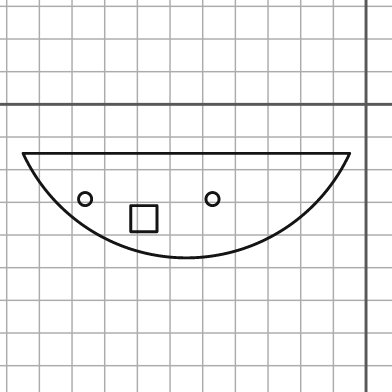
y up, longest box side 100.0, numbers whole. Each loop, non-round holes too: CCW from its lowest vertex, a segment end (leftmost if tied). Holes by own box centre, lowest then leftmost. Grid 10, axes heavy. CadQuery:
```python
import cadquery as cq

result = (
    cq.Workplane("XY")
    .moveTo(-105.0, -15.0)
    .threePointArc((-55.0, -47.0), (-5.0, -15.0))
    .close()
    .moveTo(-72.0, -39.0)
    .lineTo(-64.0, -39.0)
    .lineTo(-64.0, -31.0)
    .lineTo(-72.0, -31.0)
    .close()
    .moveTo(-86.0, -29.0)
    .circle(2.0)
    .moveTo(-47.0, -29.0)
    .circle(2.0)
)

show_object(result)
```